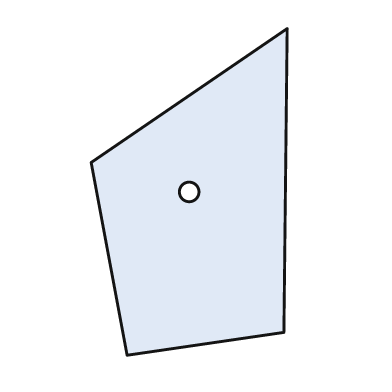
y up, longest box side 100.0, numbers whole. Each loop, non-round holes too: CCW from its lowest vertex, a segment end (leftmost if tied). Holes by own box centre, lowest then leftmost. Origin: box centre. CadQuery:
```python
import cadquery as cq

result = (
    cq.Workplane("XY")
    .moveTo(-19.0, -50.0)
    .lineTo(29.0, -43.0)
    .lineTo(30.0, 50.0)
    .lineTo(-30.0, 9.0)
    .close()
    .moveTo(0.0, 0.0)
    .circle(3.0)
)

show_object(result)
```